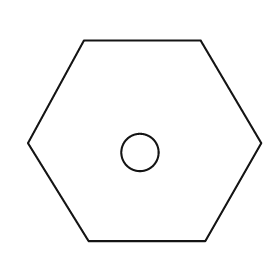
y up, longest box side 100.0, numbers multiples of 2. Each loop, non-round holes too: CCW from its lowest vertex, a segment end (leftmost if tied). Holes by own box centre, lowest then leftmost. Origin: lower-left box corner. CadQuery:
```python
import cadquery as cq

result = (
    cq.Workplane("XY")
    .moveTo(26.0, 0.0)
    .lineTo(76.0, 0.0)
    .lineTo(100.0, 42.0)
    .lineTo(74.0, 86.0)
    .lineTo(24.0, 86.0)
    .lineTo(0.0, 42.0)
    .close()
    .moveTo(48.0, 38.0)
    .circle(8.0)
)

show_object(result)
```